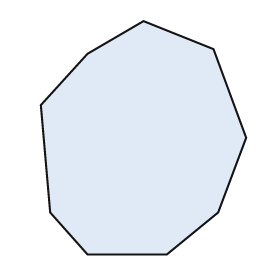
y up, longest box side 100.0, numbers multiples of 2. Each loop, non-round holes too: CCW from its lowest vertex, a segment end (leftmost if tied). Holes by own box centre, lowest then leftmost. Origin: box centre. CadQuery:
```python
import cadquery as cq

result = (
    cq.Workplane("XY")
    .moveTo(-24.0, -50.0)
    .lineTo(10.0, -50.0)
    .lineTo(32.0, -32.0)
    .lineTo(44.0, 0.0)
    .lineTo(30.0, 38.0)
    .lineTo(0.0, 50.0)
    .lineTo(-24.0, 36.0)
    .lineTo(-44.0, 14.0)
    .lineTo(-40.0, -32.0)
    .close()
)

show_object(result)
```